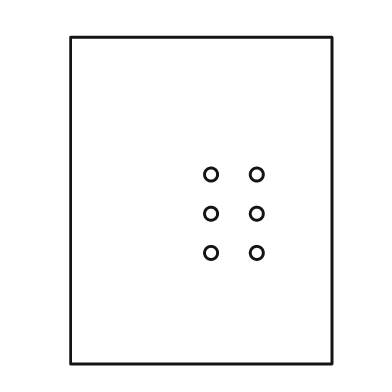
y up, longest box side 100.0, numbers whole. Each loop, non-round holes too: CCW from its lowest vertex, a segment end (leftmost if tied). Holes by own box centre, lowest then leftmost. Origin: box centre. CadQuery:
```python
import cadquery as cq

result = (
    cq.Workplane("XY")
    .moveTo(-40.0, -50.0)
    .lineTo(40.0, -50.0)
    .lineTo(40.0, 50.0)
    .lineTo(-40.0, 50.0)
    .close()
    .moveTo(3.0, -16.0)
    .circle(2.0)
    .moveTo(17.0, -16.0)
    .circle(2.0)
    .moveTo(3.0, -4.0)
    .circle(2.0)
    .moveTo(17.0, -4.0)
    .circle(2.0)
    .moveTo(3.0, 8.0)
    .circle(2.0)
    .moveTo(17.0, 8.0)
    .circle(2.0)
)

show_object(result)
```